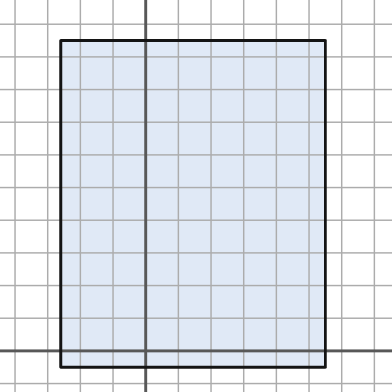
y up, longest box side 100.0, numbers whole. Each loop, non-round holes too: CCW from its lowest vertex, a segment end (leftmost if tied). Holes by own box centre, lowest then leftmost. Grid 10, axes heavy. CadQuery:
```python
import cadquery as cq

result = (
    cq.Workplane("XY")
    .moveTo(-26.0, -5.0)
    .lineTo(55.0, -5.0)
    .lineTo(55.0, 95.0)
    .lineTo(-26.0, 95.0)
    .close()
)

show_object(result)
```